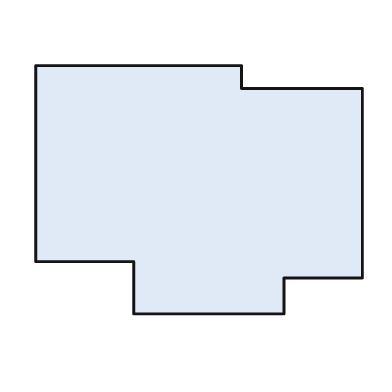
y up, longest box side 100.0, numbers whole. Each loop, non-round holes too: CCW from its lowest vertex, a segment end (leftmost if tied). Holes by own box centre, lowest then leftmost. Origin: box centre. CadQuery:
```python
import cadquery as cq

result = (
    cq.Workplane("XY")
    .moveTo(-20.0, -38.0)
    .lineTo(26.0, -38.0)
    .lineTo(26.0, -27.0)
    .lineTo(50.0, -27.0)
    .lineTo(50.0, 31.0)
    .lineTo(13.0, 31.0)
    .lineTo(13.0, 38.0)
    .lineTo(-50.0, 38.0)
    .lineTo(-50.0, -22.0)
    .lineTo(-20.0, -22.0)
    .close()
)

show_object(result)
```